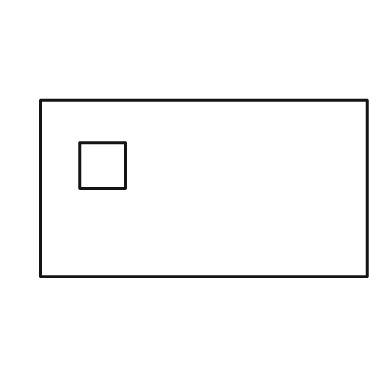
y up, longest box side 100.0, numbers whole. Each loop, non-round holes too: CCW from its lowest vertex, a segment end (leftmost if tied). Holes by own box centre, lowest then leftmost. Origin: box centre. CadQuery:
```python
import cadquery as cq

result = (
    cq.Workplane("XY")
    .moveTo(-50.0, -27.0)
    .lineTo(50.0, -27.0)
    .lineTo(50.0, 27.0)
    .lineTo(-50.0, 27.0)
    .close()
    .moveTo(-38.0, 0.0)
    .lineTo(-24.0, 0.0)
    .lineTo(-24.0, 14.0)
    .lineTo(-38.0, 14.0)
    .close()
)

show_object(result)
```